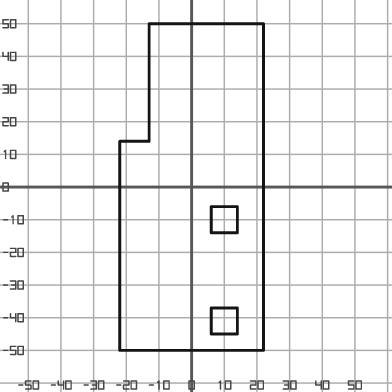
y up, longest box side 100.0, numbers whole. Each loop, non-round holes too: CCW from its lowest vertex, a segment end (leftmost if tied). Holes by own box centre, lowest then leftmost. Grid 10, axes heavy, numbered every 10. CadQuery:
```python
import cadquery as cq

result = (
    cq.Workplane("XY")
    .moveTo(-22.0, -50.0)
    .lineTo(22.0, -50.0)
    .lineTo(22.0, 50.0)
    .lineTo(-13.0, 50.0)
    .lineTo(-13.0, 14.0)
    .lineTo(-22.0, 14.0)
    .close()
    .moveTo(6.0, -45.0)
    .lineTo(14.0, -45.0)
    .lineTo(14.0, -37.0)
    .lineTo(6.0, -37.0)
    .close()
    .moveTo(6.0, -14.0)
    .lineTo(14.0, -14.0)
    .lineTo(14.0, -6.0)
    .lineTo(6.0, -6.0)
    .close()
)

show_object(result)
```